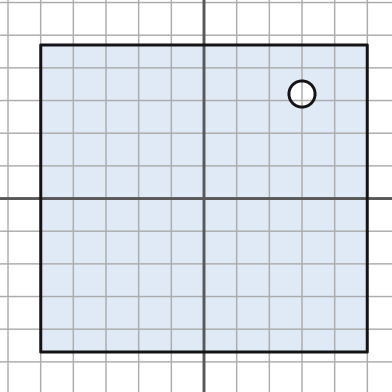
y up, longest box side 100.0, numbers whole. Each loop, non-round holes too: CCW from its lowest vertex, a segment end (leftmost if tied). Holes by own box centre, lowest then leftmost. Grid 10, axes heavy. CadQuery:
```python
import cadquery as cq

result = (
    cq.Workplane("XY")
    .moveTo(-50.0, -47.0)
    .lineTo(50.0, -47.0)
    .lineTo(50.0, 47.0)
    .lineTo(-50.0, 47.0)
    .close()
    .moveTo(30.0, 32.0)
    .circle(4.0)
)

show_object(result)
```